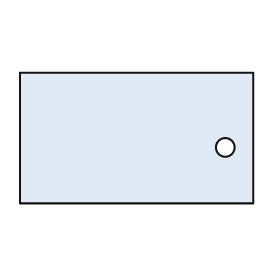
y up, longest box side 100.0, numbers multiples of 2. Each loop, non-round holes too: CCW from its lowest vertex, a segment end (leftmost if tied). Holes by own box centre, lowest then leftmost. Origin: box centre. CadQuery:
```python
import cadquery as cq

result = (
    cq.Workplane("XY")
    .moveTo(-50.0, -28.0)
    .lineTo(50.0, -28.0)
    .lineTo(50.0, 28.0)
    .lineTo(-50.0, 28.0)
    .close()
    .moveTo(38.0, -4.0)
    .circle(4.0)
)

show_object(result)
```